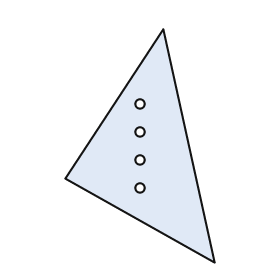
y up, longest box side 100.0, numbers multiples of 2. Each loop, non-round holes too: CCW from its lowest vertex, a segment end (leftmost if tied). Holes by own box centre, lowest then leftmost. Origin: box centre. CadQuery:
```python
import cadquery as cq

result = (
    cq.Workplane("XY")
    .moveTo(32.0, -50.0)
    .lineTo(10.0, 50.0)
    .lineTo(-32.0, -14.0)
    .close()
    .moveTo(0.0, -18.0)
    .circle(2.0)
    .moveTo(0.0, -6.0)
    .circle(2.0)
    .moveTo(0.0, 6.0)
    .circle(2.0)
    .moveTo(0.0, 18.0)
    .circle(2.0)
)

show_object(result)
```